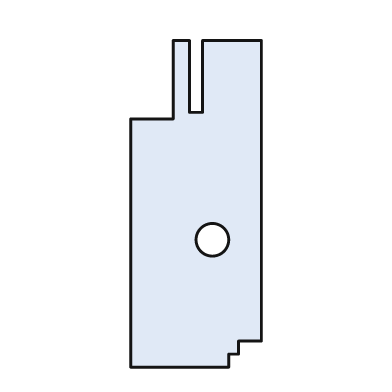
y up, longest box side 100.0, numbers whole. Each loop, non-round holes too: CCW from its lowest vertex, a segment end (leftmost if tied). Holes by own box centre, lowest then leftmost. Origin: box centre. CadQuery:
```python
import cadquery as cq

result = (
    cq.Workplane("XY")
    .moveTo(-20.0, -50.0)
    .lineTo(10.0, -50.0)
    .lineTo(10.0, -46.0)
    .lineTo(13.0, -46.0)
    .lineTo(13.0, -42.0)
    .lineTo(20.0, -42.0)
    .lineTo(20.0, 50.0)
    .lineTo(2.0, 50.0)
    .lineTo(2.0, 28.0)
    .lineTo(-2.0, 28.0)
    .lineTo(-2.0, 50.0)
    .lineTo(-7.0, 50.0)
    .lineTo(-7.0, 26.0)
    .lineTo(-20.0, 26.0)
    .close()
    .moveTo(5.0, -11.0)
    .circle(5.0)
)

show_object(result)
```